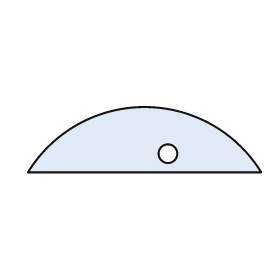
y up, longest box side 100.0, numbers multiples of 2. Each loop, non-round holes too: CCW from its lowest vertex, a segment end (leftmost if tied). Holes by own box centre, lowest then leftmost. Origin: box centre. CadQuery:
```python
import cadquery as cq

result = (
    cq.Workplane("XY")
    .moveTo(-50.0, -14.0)
    .lineTo(50.0, -14.0)
    .threePointArc((0.0, 14.0), (-50.0, -14.0))
    .close()
    .moveTo(10.0, -6.0)
    .circle(4.0)
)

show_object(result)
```